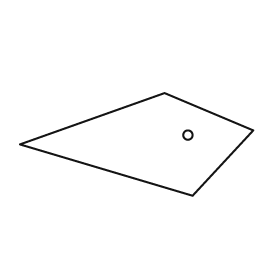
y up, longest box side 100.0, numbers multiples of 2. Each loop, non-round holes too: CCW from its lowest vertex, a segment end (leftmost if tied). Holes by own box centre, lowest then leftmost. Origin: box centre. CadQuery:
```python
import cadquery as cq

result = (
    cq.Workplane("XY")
    .moveTo(24.0, -22.0)
    .lineTo(50.0, 6.0)
    .lineTo(12.0, 22.0)
    .lineTo(-50.0, 0.0)
    .close()
    .moveTo(22.0, 4.0)
    .circle(2.0)
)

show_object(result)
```